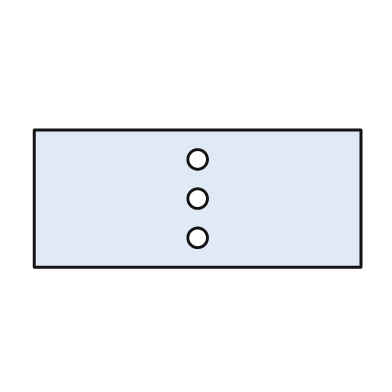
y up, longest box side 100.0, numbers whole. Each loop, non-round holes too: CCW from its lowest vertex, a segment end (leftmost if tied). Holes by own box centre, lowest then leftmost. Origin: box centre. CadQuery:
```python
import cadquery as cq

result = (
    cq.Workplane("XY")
    .moveTo(-50.0, -21.0)
    .lineTo(50.0, -21.0)
    .lineTo(50.0, 21.0)
    .lineTo(-50.0, 21.0)
    .close()
    .moveTo(0.0, -12.0)
    .circle(3.0)
    .moveTo(0.0, 0.0)
    .circle(3.0)
    .moveTo(0.0, 12.0)
    .circle(3.0)
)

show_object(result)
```